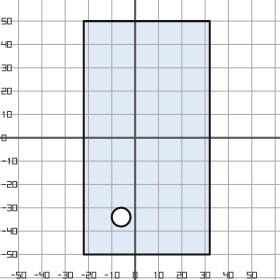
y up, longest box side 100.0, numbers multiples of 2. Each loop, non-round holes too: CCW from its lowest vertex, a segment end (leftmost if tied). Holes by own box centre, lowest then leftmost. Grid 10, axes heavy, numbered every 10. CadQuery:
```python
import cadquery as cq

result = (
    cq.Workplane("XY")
    .moveTo(-22.0, -50.0)
    .lineTo(32.0, -50.0)
    .lineTo(32.0, 50.0)
    .lineTo(-22.0, 50.0)
    .close()
    .moveTo(-6.0, -34.0)
    .circle(4.0)
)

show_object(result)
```